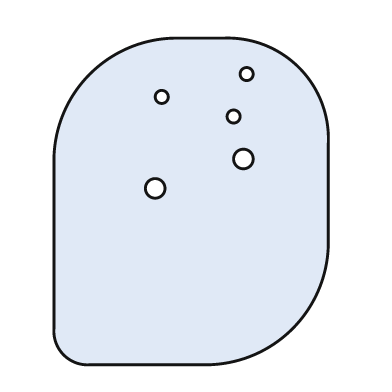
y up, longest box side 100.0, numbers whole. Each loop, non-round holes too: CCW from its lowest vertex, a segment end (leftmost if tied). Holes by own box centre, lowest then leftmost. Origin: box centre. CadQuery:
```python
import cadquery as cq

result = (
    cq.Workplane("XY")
    .moveTo(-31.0, -50.0)
    .lineTo(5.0, -50.0)
    .threePointArc((31.0, -39.0), (42.0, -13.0))
    .lineTo(42.0, 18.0)
    .threePointArc((33.0, 41.0), (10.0, 50.0))
    .lineTo(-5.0, 50.0)
    .threePointArc((-31.0, 39.0), (-42.0, 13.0))
    .lineTo(-42.0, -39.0)
    .threePointArc((-39.0, -47.0), (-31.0, -50.0))
    .close()
    .moveTo(-11.0, 4.0)
    .circle(3.0)
    .moveTo(16.0, 13.0)
    .circle(3.0)
    .moveTo(13.0, 26.0)
    .circle(2.0)
    .moveTo(-9.0, 32.0)
    .circle(2.0)
    .moveTo(17.0, 39.0)
    .circle(2.0)
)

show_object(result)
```